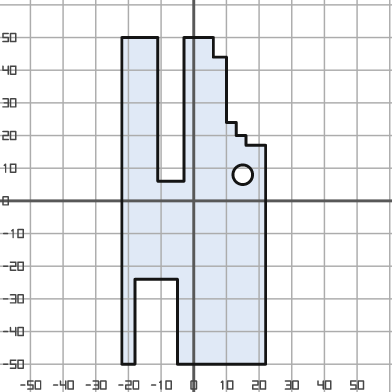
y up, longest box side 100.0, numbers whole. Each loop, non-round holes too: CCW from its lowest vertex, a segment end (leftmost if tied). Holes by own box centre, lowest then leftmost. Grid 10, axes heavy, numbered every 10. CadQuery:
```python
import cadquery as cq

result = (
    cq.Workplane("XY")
    .moveTo(-22.0, -50.0)
    .lineTo(-18.0, -50.0)
    .lineTo(-18.0, -24.0)
    .lineTo(-5.0, -24.0)
    .lineTo(-5.0, -50.0)
    .lineTo(22.0, -50.0)
    .lineTo(22.0, 17.0)
    .lineTo(16.0, 17.0)
    .lineTo(16.0, 20.0)
    .lineTo(13.0, 20.0)
    .lineTo(13.0, 24.0)
    .lineTo(10.0, 24.0)
    .lineTo(10.0, 44.0)
    .lineTo(6.0, 44.0)
    .lineTo(6.0, 50.0)
    .lineTo(-3.0, 50.0)
    .lineTo(-3.0, 6.0)
    .lineTo(-11.0, 6.0)
    .lineTo(-11.0, 50.0)
    .lineTo(-22.0, 50.0)
    .close()
    .moveTo(15.0, 8.0)
    .circle(3.0)
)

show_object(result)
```